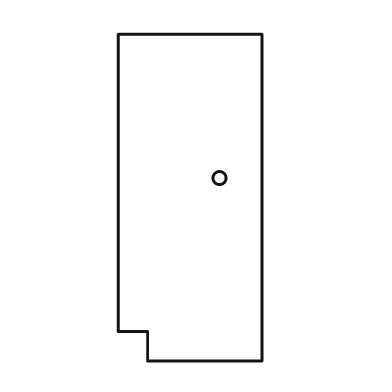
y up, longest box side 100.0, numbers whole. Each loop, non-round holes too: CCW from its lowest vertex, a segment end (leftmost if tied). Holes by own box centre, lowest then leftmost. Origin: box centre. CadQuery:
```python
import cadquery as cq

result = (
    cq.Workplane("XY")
    .moveTo(-13.0, -50.0)
    .lineTo(22.0, -50.0)
    .lineTo(22.0, 50.0)
    .lineTo(-22.0, 50.0)
    .lineTo(-22.0, -41.0)
    .lineTo(-13.0, -41.0)
    .close()
    .moveTo(9.0, 6.0)
    .circle(2.0)
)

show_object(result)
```